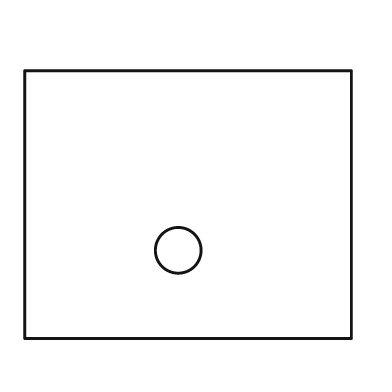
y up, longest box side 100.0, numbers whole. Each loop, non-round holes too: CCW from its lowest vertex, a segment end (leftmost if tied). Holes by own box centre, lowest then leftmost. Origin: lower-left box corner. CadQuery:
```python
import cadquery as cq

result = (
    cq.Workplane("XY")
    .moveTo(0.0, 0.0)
    .lineTo(100.0, 0.0)
    .lineTo(100.0, 82.0)
    .lineTo(0.0, 82.0)
    .close()
    .moveTo(47.0, 27.0)
    .circle(7.0)
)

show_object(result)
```